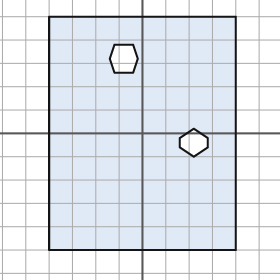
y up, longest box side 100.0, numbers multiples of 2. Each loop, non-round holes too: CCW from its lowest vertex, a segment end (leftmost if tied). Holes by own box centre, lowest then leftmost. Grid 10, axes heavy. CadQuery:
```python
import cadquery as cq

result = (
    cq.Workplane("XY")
    .moveTo(-40.0, -50.0)
    .lineTo(40.0, -50.0)
    .lineTo(40.0, 50.0)
    .lineTo(-40.0, 50.0)
    .close()
    .moveTo(22.0, -10.0)
    .lineTo(28.0, -6.0)
    .lineTo(28.0, -2.0)
    .lineTo(22.0, 2.0)
    .lineTo(16.0, -2.0)
    .lineTo(16.0, -6.0)
    .close()
    .moveTo(-12.0, 26.0)
    .lineTo(-4.0, 26.0)
    .lineTo(-2.0, 32.0)
    .lineTo(-4.0, 38.0)
    .lineTo(-12.0, 38.0)
    .lineTo(-14.0, 32.0)
    .close()
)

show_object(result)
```